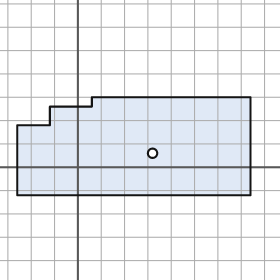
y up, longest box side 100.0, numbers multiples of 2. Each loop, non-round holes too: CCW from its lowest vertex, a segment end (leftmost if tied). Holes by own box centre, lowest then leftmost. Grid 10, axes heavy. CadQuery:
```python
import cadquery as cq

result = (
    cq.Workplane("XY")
    .moveTo(-26.0, -12.0)
    .lineTo(74.0, -12.0)
    .lineTo(74.0, 30.0)
    .lineTo(6.0, 30.0)
    .lineTo(6.0, 26.0)
    .lineTo(-12.0, 26.0)
    .lineTo(-12.0, 18.0)
    .lineTo(-26.0, 18.0)
    .close()
    .moveTo(32.0, 6.0)
    .circle(2.0)
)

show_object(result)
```